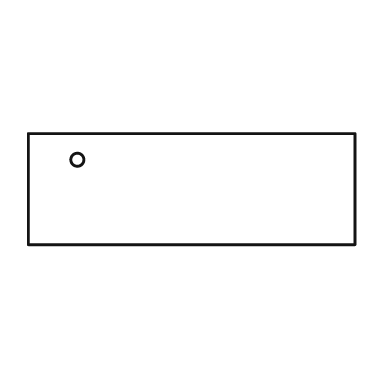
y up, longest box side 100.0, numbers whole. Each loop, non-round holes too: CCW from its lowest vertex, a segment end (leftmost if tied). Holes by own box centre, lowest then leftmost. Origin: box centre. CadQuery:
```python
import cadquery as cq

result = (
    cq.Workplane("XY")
    .moveTo(-50.0, -17.0)
    .lineTo(50.0, -17.0)
    .lineTo(50.0, 17.0)
    .lineTo(-50.0, 17.0)
    .close()
    .moveTo(-35.0, 9.0)
    .circle(2.0)
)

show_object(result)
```